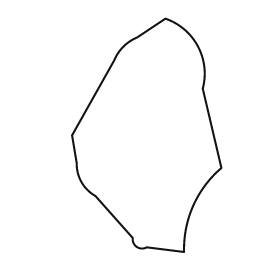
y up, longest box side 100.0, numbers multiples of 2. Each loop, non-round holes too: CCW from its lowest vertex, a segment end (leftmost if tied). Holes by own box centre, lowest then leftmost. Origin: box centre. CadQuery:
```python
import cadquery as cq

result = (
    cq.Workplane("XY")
    .moveTo(16.0, -50.0)
    .threePointArc((20.0, -30.0), (32.0, -14.0))
    .lineTo(24.0, 20.0)
    .threePointArc((22.0, 38.0), (8.0, 50.0))
    .lineTo(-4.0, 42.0)
    .threePointArc((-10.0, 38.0), (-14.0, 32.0))
    .lineTo(-32.0, 0.0)
    .lineTo(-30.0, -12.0)
    .threePointArc((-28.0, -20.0), (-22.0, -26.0))
    .lineTo(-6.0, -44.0)
    .threePointArc((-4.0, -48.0), (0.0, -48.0))
    .close()
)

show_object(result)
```